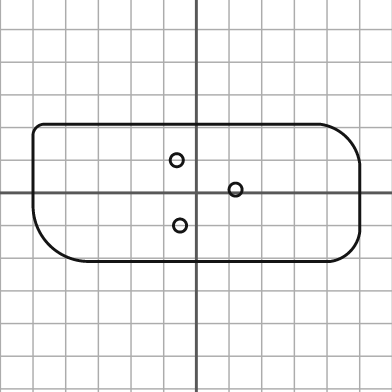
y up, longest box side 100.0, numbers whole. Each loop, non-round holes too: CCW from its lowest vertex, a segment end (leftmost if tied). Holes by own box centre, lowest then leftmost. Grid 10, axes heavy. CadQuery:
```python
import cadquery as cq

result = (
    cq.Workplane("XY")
    .moveTo(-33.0, -21.0)
    .lineTo(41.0, -21.0)
    .threePointArc((47.0, -18.0), (50.0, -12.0))
    .lineTo(50.0, 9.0)
    .threePointArc((46.0, 17.0), (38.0, 21.0))
    .lineTo(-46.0, 21.0)
    .threePointArc((-49.0, 20.0), (-50.0, 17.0))
    .lineTo(-50.0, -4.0)
    .threePointArc((-45.0, -16.0), (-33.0, -21.0))
    .close()
    .moveTo(-5.0, -10.0)
    .circle(2.0)
    .moveTo(12.0, 1.0)
    .circle(2.0)
    .moveTo(-6.0, 10.0)
    .circle(2.0)
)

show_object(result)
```